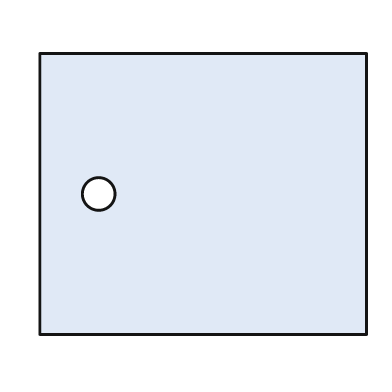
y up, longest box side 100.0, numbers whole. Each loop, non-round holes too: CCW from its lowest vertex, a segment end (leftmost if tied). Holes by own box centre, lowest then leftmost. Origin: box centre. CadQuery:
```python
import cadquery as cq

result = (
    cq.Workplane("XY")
    .moveTo(-50.0, -43.0)
    .lineTo(50.0, -43.0)
    .lineTo(50.0, 43.0)
    .lineTo(-50.0, 43.0)
    .close()
    .moveTo(-32.0, 0.0)
    .circle(5.0)
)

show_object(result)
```